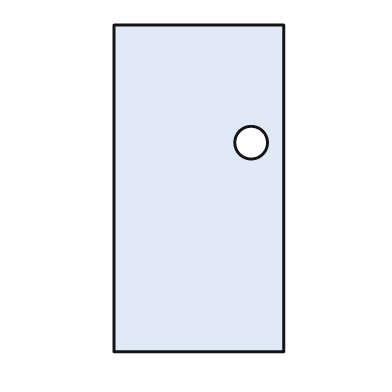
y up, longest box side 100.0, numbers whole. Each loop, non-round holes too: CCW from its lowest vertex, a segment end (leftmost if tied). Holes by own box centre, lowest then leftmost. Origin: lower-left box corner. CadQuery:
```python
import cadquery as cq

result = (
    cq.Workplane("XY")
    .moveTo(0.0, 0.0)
    .lineTo(52.0, 0.0)
    .lineTo(52.0, 100.0)
    .lineTo(0.0, 100.0)
    .close()
    .moveTo(42.0, 64.0)
    .circle(5.0)
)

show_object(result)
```